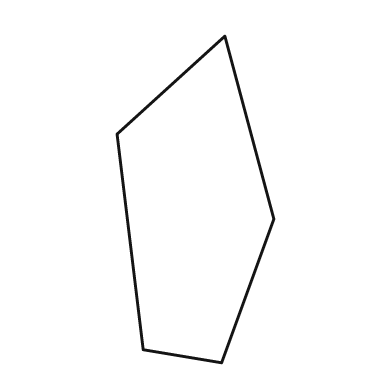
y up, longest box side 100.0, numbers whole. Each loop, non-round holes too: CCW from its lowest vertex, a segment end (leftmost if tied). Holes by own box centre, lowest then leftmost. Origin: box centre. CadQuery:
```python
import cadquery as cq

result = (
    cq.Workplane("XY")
    .moveTo(8.0, -50.0)
    .lineTo(24.0, -6.0)
    .lineTo(9.0, 50.0)
    .lineTo(-24.0, 20.0)
    .lineTo(-16.0, -46.0)
    .close()
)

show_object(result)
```